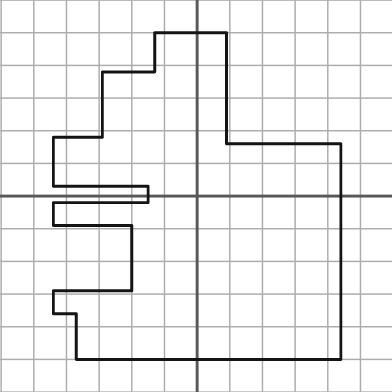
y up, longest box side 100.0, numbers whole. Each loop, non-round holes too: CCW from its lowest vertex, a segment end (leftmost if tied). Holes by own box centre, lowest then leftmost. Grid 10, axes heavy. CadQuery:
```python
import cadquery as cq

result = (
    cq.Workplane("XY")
    .moveTo(-37.0, -50.0)
    .lineTo(44.0, -50.0)
    .lineTo(44.0, 16.0)
    .lineTo(9.0, 16.0)
    .lineTo(9.0, 50.0)
    .lineTo(-13.0, 50.0)
    .lineTo(-13.0, 38.0)
    .lineTo(-29.0, 38.0)
    .lineTo(-29.0, 18.0)
    .lineTo(-44.0, 18.0)
    .lineTo(-44.0, 3.0)
    .lineTo(-15.0, 3.0)
    .lineTo(-15.0, -2.0)
    .lineTo(-44.0, -2.0)
    .lineTo(-44.0, -9.0)
    .lineTo(-20.0, -9.0)
    .lineTo(-20.0, -29.0)
    .lineTo(-44.0, -29.0)
    .lineTo(-44.0, -36.0)
    .lineTo(-37.0, -36.0)
    .close()
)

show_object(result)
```